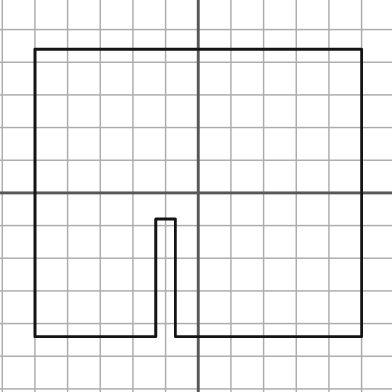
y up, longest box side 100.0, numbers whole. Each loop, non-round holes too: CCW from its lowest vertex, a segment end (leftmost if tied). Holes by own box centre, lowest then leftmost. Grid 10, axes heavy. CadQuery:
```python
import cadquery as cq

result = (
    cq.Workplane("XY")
    .moveTo(-50.0, -44.0)
    .lineTo(-13.0, -44.0)
    .lineTo(-13.0, -8.0)
    .lineTo(-7.0, -8.0)
    .lineTo(-7.0, -44.0)
    .lineTo(50.0, -44.0)
    .lineTo(50.0, 44.0)
    .lineTo(-50.0, 44.0)
    .close()
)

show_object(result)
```